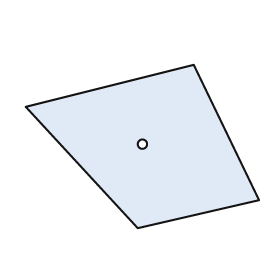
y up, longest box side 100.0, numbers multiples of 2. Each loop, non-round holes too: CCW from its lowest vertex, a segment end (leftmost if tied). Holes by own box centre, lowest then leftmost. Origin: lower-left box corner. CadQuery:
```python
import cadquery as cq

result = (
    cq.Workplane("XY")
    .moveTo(48.0, 0.0)
    .lineTo(100.0, 12.0)
    .lineTo(72.0, 70.0)
    .lineTo(0.0, 52.0)
    .close()
    .moveTo(50.0, 36.0)
    .circle(2.0)
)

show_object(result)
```